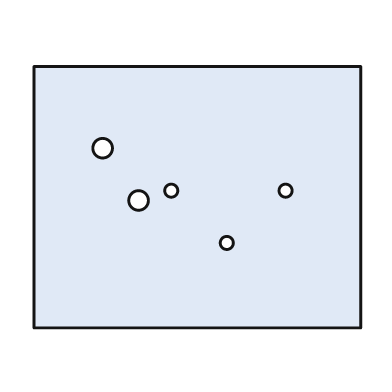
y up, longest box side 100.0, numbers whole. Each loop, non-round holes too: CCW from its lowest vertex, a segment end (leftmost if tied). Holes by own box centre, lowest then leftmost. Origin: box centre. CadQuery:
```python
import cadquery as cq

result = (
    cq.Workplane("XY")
    .moveTo(-50.0, -40.0)
    .lineTo(50.0, -40.0)
    .lineTo(50.0, 40.0)
    .lineTo(-50.0, 40.0)
    .close()
    .moveTo(9.0, -14.0)
    .circle(2.0)
    .moveTo(-18.0, -1.0)
    .circle(3.0)
    .moveTo(-8.0, 2.0)
    .circle(2.0)
    .moveTo(27.0, 2.0)
    .circle(2.0)
    .moveTo(-29.0, 15.0)
    .circle(3.0)
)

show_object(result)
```